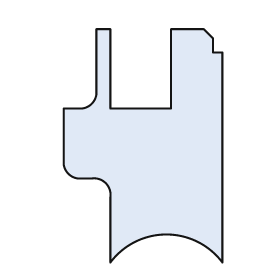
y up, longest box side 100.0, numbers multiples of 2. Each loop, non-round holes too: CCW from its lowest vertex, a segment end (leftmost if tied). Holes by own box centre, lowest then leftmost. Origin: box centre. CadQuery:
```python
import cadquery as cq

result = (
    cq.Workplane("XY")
    .moveTo(-14.0, -50.0)
    .threePointArc((10.0, -38.0), (34.0, -50.0))
    .lineTo(34.0, 40.0)
    .lineTo(30.0, 40.0)
    .lineTo(30.0, 46.0)
    .lineTo(26.0, 50.0)
    .lineTo(12.0, 50.0)
    .lineTo(12.0, 16.0)
    .lineTo(-14.0, 16.0)
    .lineTo(-14.0, 50.0)
    .lineTo(-20.0, 50.0)
    .lineTo(-20.0, 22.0)
    .threePointArc((-22.0, 18.0), (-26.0, 16.0))
    .lineTo(-34.0, 16.0)
    .lineTo(-34.0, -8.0)
    .threePointArc((-32.0, -12.0), (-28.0, -14.0))
    .lineTo(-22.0, -14.0)
    .threePointArc((-16.0, -16.0), (-14.0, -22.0))
    .close()
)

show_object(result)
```